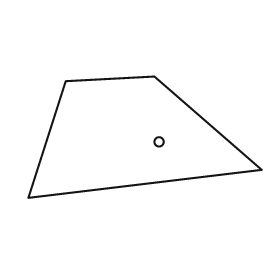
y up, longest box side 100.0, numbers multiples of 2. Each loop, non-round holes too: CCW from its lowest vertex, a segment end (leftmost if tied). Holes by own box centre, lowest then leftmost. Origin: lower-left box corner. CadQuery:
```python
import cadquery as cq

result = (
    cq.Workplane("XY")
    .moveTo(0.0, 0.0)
    .lineTo(100.0, 12.0)
    .lineTo(54.0, 52.0)
    .lineTo(16.0, 50.0)
    .close()
    .moveTo(56.0, 24.0)
    .circle(2.0)
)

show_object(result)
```